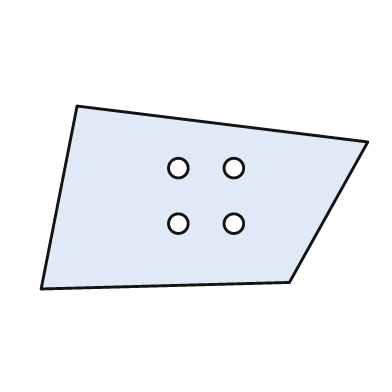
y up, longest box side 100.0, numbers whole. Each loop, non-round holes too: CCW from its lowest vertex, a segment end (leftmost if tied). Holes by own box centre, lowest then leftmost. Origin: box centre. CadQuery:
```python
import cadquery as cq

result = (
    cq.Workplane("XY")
    .moveTo(-50.0, -28.0)
    .lineTo(26.0, -26.0)
    .lineTo(50.0, 17.0)
    .lineTo(-39.0, 28.0)
    .close()
    .moveTo(-8.0, -8.0)
    .circle(3.0)
    .moveTo(9.0, -8.0)
    .circle(3.0)
    .moveTo(-8.0, 9.0)
    .circle(3.0)
    .moveTo(9.0, 9.0)
    .circle(3.0)
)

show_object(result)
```